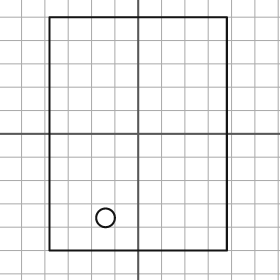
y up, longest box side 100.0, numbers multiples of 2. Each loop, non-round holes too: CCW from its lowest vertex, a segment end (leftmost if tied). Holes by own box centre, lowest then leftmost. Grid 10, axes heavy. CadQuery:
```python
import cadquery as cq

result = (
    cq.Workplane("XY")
    .moveTo(-38.0, -50.0)
    .lineTo(38.0, -50.0)
    .lineTo(38.0, 50.0)
    .lineTo(-38.0, 50.0)
    .close()
    .moveTo(-14.0, -36.0)
    .circle(4.0)
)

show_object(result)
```